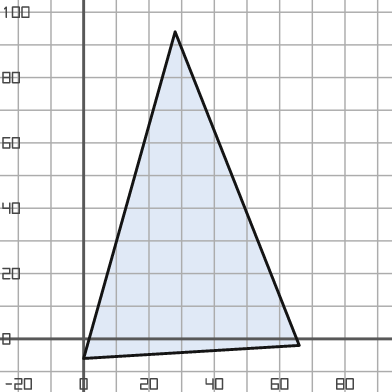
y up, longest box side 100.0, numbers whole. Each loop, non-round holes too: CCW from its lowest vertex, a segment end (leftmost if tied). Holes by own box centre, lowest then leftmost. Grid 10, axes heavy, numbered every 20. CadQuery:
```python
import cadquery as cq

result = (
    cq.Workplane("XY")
    .moveTo(0.0, -6.0)
    .lineTo(66.0, -2.0)
    .lineTo(28.0, 94.0)
    .close()
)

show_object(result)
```